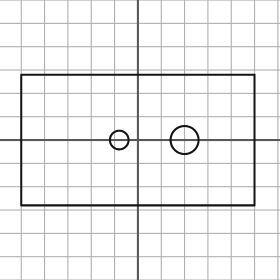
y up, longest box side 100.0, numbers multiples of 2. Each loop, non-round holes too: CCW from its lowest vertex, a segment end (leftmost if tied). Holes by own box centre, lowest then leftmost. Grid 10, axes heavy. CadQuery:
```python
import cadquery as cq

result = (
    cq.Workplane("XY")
    .moveTo(-50.0, -28.0)
    .lineTo(50.0, -28.0)
    .lineTo(50.0, 28.0)
    .lineTo(-50.0, 28.0)
    .close()
    .moveTo(-8.0, 0.0)
    .circle(4.0)
    .moveTo(20.0, 0.0)
    .circle(6.0)
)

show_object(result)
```